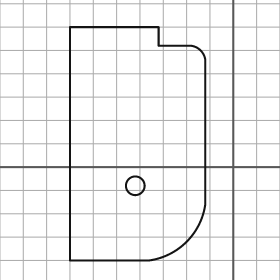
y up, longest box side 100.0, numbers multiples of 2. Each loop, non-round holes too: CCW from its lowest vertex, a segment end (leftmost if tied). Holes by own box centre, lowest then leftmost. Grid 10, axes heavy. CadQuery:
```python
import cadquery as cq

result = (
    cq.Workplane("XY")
    .moveTo(-70.0, -40.0)
    .lineTo(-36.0, -40.0)
    .threePointArc((-20.0, -32.0), (-12.0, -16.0))
    .lineTo(-12.0, 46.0)
    .threePointArc((-14.0, 50.0), (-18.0, 52.0))
    .lineTo(-32.0, 52.0)
    .lineTo(-32.0, 60.0)
    .lineTo(-70.0, 60.0)
    .close()
    .moveTo(-42.0, -8.0)
    .circle(4.0)
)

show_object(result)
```